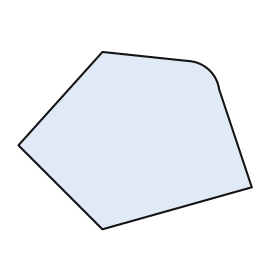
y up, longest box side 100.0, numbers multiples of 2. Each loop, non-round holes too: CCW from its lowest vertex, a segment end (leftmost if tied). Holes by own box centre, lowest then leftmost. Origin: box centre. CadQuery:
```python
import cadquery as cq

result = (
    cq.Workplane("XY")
    .moveTo(-14.0, -38.0)
    .lineTo(50.0, -20.0)
    .lineTo(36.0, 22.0)
    .threePointArc((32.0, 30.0), (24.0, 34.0))
    .lineTo(-14.0, 38.0)
    .lineTo(-50.0, -2.0)
    .close()
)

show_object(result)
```